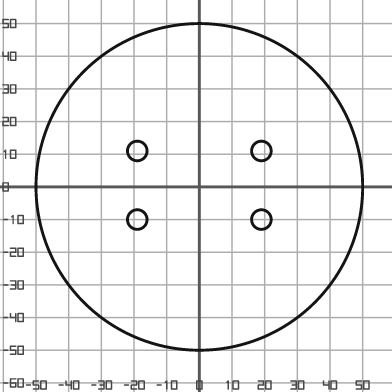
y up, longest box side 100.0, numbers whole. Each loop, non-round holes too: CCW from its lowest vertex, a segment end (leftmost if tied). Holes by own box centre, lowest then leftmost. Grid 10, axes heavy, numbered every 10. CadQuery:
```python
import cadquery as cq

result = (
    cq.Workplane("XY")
    .moveTo(0.0, 0.0)
    .circle(50.0)
    .moveTo(-19.0, -10.0)
    .circle(3.0)
    .moveTo(19.0, -10.0)
    .circle(3.0)
    .moveTo(-19.0, 11.0)
    .circle(3.0)
    .moveTo(19.0, 11.0)
    .circle(3.0)
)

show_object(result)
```